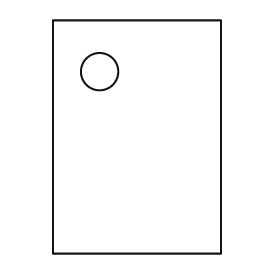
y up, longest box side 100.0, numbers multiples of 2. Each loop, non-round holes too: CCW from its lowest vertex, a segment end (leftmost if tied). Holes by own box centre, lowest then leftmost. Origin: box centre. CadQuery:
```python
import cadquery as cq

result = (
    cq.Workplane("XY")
    .moveTo(-36.0, -50.0)
    .lineTo(36.0, -50.0)
    .lineTo(36.0, 50.0)
    .lineTo(-36.0, 50.0)
    .close()
    .moveTo(-16.0, 28.0)
    .circle(8.0)
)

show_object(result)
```